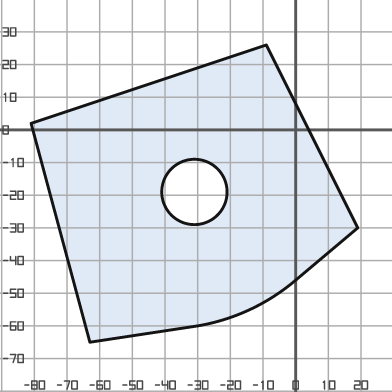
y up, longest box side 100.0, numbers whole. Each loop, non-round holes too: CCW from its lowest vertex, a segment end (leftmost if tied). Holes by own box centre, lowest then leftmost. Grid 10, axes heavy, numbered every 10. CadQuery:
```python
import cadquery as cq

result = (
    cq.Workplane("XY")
    .moveTo(-63.0, -65.0)
    .lineTo(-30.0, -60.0)
    .threePointArc((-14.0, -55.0), (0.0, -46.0))
    .lineTo(19.0, -30.0)
    .lineTo(-9.0, 26.0)
    .lineTo(-81.0, 2.0)
    .close()
    .moveTo(-31.0, -19.0)
    .circle(10.0)
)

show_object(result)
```